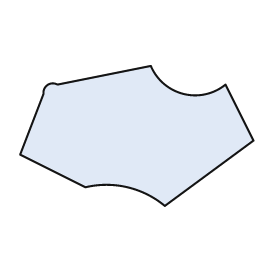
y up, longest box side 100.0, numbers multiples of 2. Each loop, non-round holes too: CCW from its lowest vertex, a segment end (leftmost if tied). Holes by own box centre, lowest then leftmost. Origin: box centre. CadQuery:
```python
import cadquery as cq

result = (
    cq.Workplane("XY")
    .moveTo(12.0, -30.0)
    .lineTo(50.0, -2.0)
    .lineTo(38.0, 22.0)
    .threePointArc((20.0, 18.0), (6.0, 30.0))
    .lineTo(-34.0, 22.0)
    .threePointArc((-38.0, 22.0), (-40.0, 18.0))
    .lineTo(-50.0, -8.0)
    .lineTo(-22.0, -22.0)
    .threePointArc((-4.0, -22.0), (12.0, -30.0))
    .close()
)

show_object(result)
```